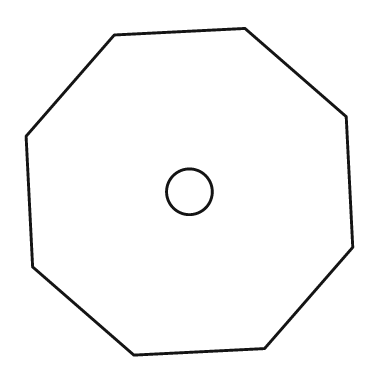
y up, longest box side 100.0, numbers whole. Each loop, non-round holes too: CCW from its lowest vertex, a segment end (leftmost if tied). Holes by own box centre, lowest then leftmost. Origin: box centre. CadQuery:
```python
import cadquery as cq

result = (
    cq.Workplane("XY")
    .moveTo(-17.0, -50.0)
    .lineTo(23.0, -48.0)
    .lineTo(50.0, -17.0)
    .lineTo(48.0, 23.0)
    .lineTo(17.0, 50.0)
    .lineTo(-23.0, 48.0)
    .lineTo(-50.0, 17.0)
    .lineTo(-48.0, -23.0)
    .close()
    .moveTo(0.0, 0.0)
    .circle(7.0)
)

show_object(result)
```